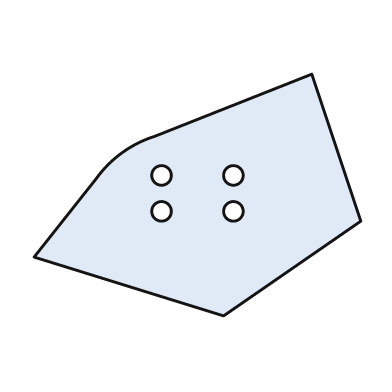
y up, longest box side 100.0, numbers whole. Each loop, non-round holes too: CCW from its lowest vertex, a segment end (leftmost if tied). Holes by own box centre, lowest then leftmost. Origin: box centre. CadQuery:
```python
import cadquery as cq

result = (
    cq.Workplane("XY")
    .moveTo(8.0, -37.0)
    .lineTo(50.0, -8.0)
    .lineTo(35.0, 37.0)
    .lineTo(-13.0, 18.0)
    .threePointArc((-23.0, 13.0), (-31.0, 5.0))
    .lineTo(-50.0, -19.0)
    .close()
    .moveTo(-11.0, -5.0)
    .circle(3.0)
    .moveTo(11.0, -5.0)
    .circle(3.0)
    .moveTo(-11.0, 6.0)
    .circle(3.0)
    .moveTo(11.0, 6.0)
    .circle(3.0)
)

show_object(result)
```